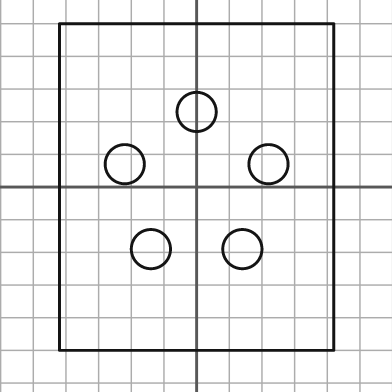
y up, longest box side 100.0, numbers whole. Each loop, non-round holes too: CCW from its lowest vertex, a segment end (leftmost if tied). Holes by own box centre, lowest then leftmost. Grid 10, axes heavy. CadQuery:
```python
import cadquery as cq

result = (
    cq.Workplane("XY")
    .moveTo(-42.0, -50.0)
    .lineTo(42.0, -50.0)
    .lineTo(42.0, 50.0)
    .lineTo(-42.0, 50.0)
    .close()
    .moveTo(-14.0, -19.0)
    .circle(6.0)
    .moveTo(14.0, -19.0)
    .circle(6.0)
    .moveTo(-22.0, 7.0)
    .circle(6.0)
    .moveTo(22.0, 7.0)
    .circle(6.0)
    .moveTo(0.0, 23.0)
    .circle(6.0)
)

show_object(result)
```